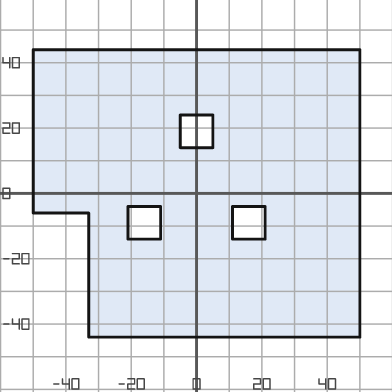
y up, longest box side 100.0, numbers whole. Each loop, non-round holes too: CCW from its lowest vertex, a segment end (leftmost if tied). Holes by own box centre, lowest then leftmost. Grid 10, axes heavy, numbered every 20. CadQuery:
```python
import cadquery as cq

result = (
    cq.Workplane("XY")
    .moveTo(-33.0, -44.0)
    .lineTo(50.0, -44.0)
    .lineTo(50.0, 44.0)
    .lineTo(-50.0, 44.0)
    .lineTo(-50.0, -6.0)
    .lineTo(-33.0, -6.0)
    .close()
    .moveTo(-21.0, -14.0)
    .lineTo(-11.0, -14.0)
    .lineTo(-11.0, -4.0)
    .lineTo(-21.0, -4.0)
    .close()
    .moveTo(11.0, -14.0)
    .lineTo(21.0, -14.0)
    .lineTo(21.0, -4.0)
    .lineTo(11.0, -4.0)
    .close()
    .moveTo(-5.0, 14.0)
    .lineTo(5.0, 14.0)
    .lineTo(5.0, 24.0)
    .lineTo(-5.0, 24.0)
    .close()
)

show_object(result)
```